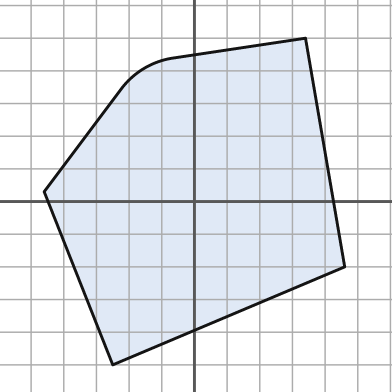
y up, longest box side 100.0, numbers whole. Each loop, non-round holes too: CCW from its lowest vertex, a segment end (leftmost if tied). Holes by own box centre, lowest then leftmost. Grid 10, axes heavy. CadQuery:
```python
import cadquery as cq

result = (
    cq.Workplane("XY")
    .moveTo(-25.0, -50.0)
    .lineTo(46.0, -20.0)
    .lineTo(34.0, 50.0)
    .lineTo(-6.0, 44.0)
    .threePointArc((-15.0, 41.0), (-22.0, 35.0))
    .lineTo(-46.0, 3.0)
    .close()
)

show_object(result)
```